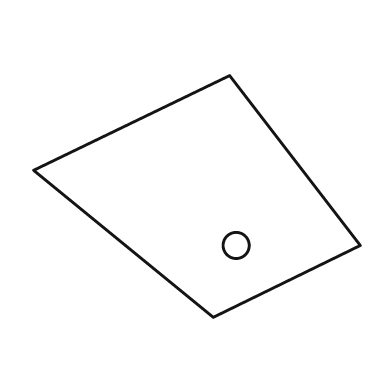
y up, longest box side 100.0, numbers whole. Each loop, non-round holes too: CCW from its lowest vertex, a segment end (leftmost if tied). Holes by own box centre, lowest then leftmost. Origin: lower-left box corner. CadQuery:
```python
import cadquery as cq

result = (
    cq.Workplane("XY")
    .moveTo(55.0, 0.0)
    .lineTo(100.0, 22.0)
    .lineTo(60.0, 74.0)
    .lineTo(0.0, 45.0)
    .close()
    .moveTo(62.0, 22.0)
    .circle(4.0)
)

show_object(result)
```